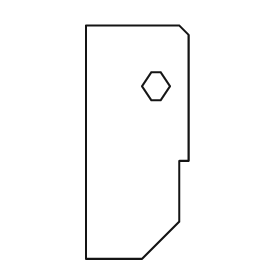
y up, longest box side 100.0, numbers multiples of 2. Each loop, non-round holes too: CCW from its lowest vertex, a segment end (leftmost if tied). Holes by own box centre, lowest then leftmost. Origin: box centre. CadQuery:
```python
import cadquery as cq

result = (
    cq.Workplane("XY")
    .moveTo(-22.0, -50.0)
    .lineTo(2.0, -50.0)
    .lineTo(18.0, -34.0)
    .lineTo(18.0, -8.0)
    .lineTo(22.0, -8.0)
    .lineTo(22.0, 46.0)
    .lineTo(18.0, 50.0)
    .lineTo(-22.0, 50.0)
    .close()
    .moveTo(6.0, 18.0)
    .lineTo(10.0, 18.0)
    .lineTo(14.0, 24.0)
    .lineTo(10.0, 30.0)
    .lineTo(6.0, 30.0)
    .lineTo(2.0, 24.0)
    .close()
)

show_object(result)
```